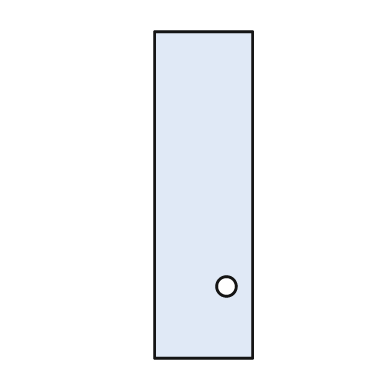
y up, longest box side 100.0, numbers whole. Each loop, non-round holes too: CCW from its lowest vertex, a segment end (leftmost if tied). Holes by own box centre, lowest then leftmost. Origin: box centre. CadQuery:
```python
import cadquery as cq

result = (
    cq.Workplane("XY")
    .moveTo(-15.0, -50.0)
    .lineTo(15.0, -50.0)
    .lineTo(15.0, 50.0)
    .lineTo(-15.0, 50.0)
    .close()
    .moveTo(7.0, -28.0)
    .circle(3.0)
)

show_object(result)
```